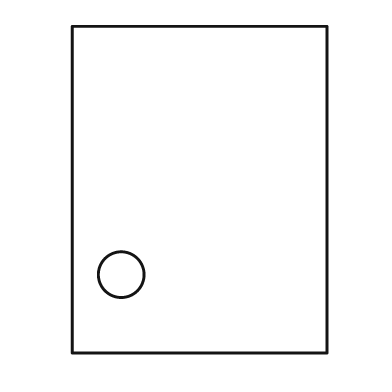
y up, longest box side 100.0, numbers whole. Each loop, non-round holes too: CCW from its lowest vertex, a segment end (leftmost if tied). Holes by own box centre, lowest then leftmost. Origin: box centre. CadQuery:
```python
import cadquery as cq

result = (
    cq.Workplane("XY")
    .moveTo(-39.0, -50.0)
    .lineTo(39.0, -50.0)
    .lineTo(39.0, 50.0)
    .lineTo(-39.0, 50.0)
    .close()
    .moveTo(-24.0, -26.0)
    .circle(7.0)
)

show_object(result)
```